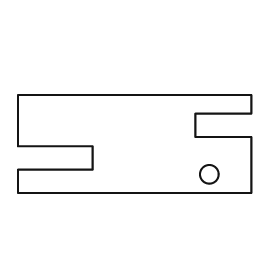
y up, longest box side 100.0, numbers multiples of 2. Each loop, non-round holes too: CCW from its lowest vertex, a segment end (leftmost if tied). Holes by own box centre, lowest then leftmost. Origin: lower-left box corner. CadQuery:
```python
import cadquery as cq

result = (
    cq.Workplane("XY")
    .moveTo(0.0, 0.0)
    .lineTo(100.0, 0.0)
    .lineTo(100.0, 24.0)
    .lineTo(76.0, 24.0)
    .lineTo(76.0, 34.0)
    .lineTo(100.0, 34.0)
    .lineTo(100.0, 42.0)
    .lineTo(0.0, 42.0)
    .lineTo(0.0, 20.0)
    .lineTo(32.0, 20.0)
    .lineTo(32.0, 10.0)
    .lineTo(0.0, 10.0)
    .close()
    .moveTo(82.0, 8.0)
    .circle(4.0)
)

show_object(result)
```